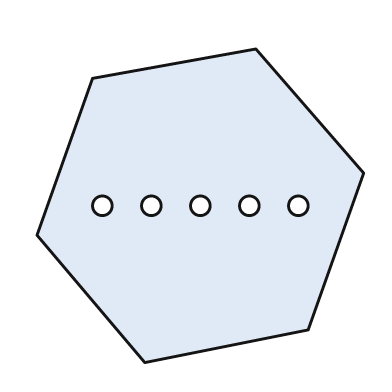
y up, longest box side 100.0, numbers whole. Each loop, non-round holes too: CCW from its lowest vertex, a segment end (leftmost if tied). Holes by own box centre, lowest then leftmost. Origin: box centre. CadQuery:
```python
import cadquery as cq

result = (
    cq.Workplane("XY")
    .moveTo(-17.0, -48.0)
    .lineTo(33.0, -38.0)
    .lineTo(50.0, 10.0)
    .lineTo(17.0, 48.0)
    .lineTo(-33.0, 39.0)
    .lineTo(-50.0, -9.0)
    .close()
    .moveTo(-30.0, 0.0)
    .circle(3.0)
    .moveTo(-15.0, 0.0)
    .circle(3.0)
    .moveTo(0.0, 0.0)
    .circle(3.0)
    .moveTo(15.0, 0.0)
    .circle(3.0)
    .moveTo(30.0, 0.0)
    .circle(3.0)
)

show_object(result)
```